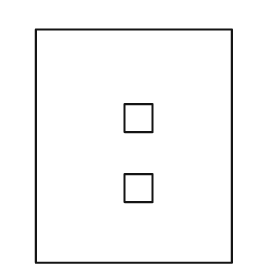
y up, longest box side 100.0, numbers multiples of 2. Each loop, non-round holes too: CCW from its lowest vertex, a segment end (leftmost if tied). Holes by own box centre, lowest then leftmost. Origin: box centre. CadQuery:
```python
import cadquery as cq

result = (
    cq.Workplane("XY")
    .moveTo(-42.0, -50.0)
    .lineTo(42.0, -50.0)
    .lineTo(42.0, 50.0)
    .lineTo(-42.0, 50.0)
    .close()
    .moveTo(-4.0, -24.0)
    .lineTo(8.0, -24.0)
    .lineTo(8.0, -12.0)
    .lineTo(-4.0, -12.0)
    .close()
    .moveTo(-4.0, 6.0)
    .lineTo(8.0, 6.0)
    .lineTo(8.0, 18.0)
    .lineTo(-4.0, 18.0)
    .close()
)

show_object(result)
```